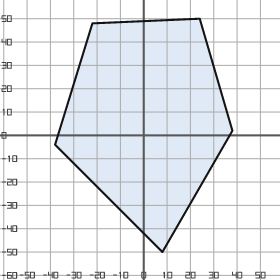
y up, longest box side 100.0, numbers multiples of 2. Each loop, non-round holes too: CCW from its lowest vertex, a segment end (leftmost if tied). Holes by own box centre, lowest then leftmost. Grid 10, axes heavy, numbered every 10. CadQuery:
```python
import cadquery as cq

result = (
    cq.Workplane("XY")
    .moveTo(8.0, -50.0)
    .lineTo(38.0, 2.0)
    .lineTo(24.0, 50.0)
    .lineTo(-22.0, 48.0)
    .lineTo(-38.0, -4.0)
    .close()
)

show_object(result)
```